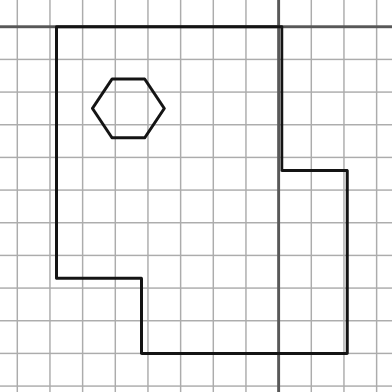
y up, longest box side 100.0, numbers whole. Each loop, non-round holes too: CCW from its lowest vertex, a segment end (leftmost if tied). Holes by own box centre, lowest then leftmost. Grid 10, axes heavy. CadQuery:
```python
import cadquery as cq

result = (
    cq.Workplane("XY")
    .moveTo(-42.0, -100.0)
    .lineTo(21.0, -100.0)
    .lineTo(21.0, -44.0)
    .lineTo(1.0, -44.0)
    .lineTo(1.0, 0.0)
    .lineTo(-68.0, 0.0)
    .lineTo(-68.0, -77.0)
    .lineTo(-42.0, -77.0)
    .close()
    .moveTo(-51.0, -34.0)
    .lineTo(-41.0, -34.0)
    .lineTo(-35.0, -25.0)
    .lineTo(-41.0, -16.0)
    .lineTo(-51.0, -16.0)
    .lineTo(-57.0, -25.0)
    .close()
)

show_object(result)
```